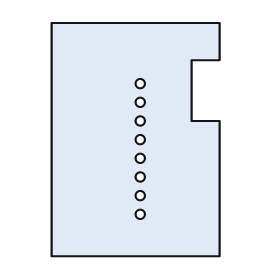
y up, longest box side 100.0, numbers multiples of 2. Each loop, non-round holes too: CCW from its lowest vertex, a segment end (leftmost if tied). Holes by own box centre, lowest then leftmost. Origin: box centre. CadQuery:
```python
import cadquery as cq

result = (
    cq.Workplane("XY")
    .moveTo(-36.0, -50.0)
    .lineTo(36.0, -50.0)
    .lineTo(36.0, 8.0)
    .lineTo(24.0, 8.0)
    .lineTo(24.0, 34.0)
    .lineTo(36.0, 34.0)
    .lineTo(36.0, 50.0)
    .lineTo(-36.0, 50.0)
    .close()
    .moveTo(2.0, -32.0)
    .circle(2.0)
    .moveTo(2.0, -24.0)
    .circle(2.0)
    .moveTo(2.0, -16.0)
    .circle(2.0)
    .moveTo(2.0, -8.0)
    .circle(2.0)
    .moveTo(2.0, 0.0)
    .circle(2.0)
    .moveTo(2.0, 8.0)
    .circle(2.0)
    .moveTo(2.0, 16.0)
    .circle(2.0)
    .moveTo(2.0, 24.0)
    .circle(2.0)
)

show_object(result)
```